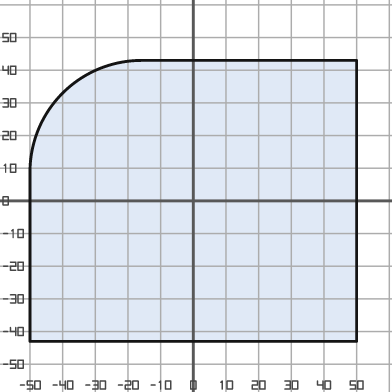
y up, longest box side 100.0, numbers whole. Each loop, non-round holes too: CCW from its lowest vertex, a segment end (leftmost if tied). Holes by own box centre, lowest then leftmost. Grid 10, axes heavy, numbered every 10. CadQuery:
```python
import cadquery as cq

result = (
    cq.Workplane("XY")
    .moveTo(-50.0, -43.0)
    .lineTo(50.0, -43.0)
    .lineTo(50.0, 43.0)
    .lineTo(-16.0, 43.0)
    .threePointArc((-40.0, 33.0), (-50.0, 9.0))
    .close()
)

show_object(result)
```